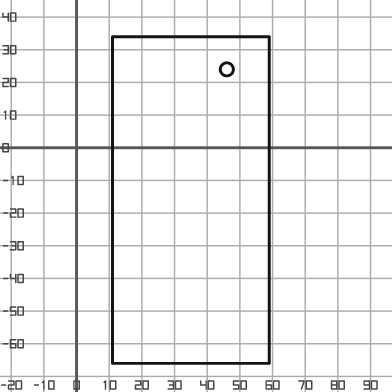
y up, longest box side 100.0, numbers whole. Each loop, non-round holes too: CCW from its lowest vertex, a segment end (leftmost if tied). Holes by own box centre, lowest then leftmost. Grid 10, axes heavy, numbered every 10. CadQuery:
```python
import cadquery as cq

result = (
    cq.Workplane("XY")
    .moveTo(11.0, -66.0)
    .lineTo(59.0, -66.0)
    .lineTo(59.0, 34.0)
    .lineTo(11.0, 34.0)
    .close()
    .moveTo(46.0, 24.0)
    .circle(2.0)
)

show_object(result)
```